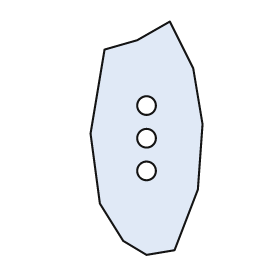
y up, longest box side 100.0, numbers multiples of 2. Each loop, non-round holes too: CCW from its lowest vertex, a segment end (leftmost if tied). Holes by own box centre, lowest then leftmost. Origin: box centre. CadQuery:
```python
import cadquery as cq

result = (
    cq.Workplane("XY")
    .moveTo(0.0, -50.0)
    .lineTo(12.0, -48.0)
    .lineTo(22.0, -22.0)
    .lineTo(24.0, 6.0)
    .lineTo(20.0, 30.0)
    .lineTo(10.0, 50.0)
    .lineTo(-4.0, 42.0)
    .lineTo(-18.0, 38.0)
    .lineTo(-24.0, 2.0)
    .lineTo(-20.0, -28.0)
    .lineTo(-10.0, -44.0)
    .close()
    .moveTo(0.0, -14.0)
    .circle(4.0)
    .moveTo(0.0, 0.0)
    .circle(4.0)
    .moveTo(0.0, 14.0)
    .circle(4.0)
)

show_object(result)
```